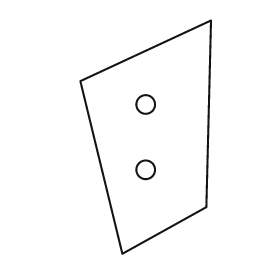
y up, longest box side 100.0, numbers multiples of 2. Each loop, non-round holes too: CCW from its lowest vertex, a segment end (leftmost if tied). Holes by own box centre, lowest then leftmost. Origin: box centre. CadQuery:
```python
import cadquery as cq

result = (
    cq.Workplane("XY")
    .moveTo(-10.0, -50.0)
    .lineTo(26.0, -30.0)
    .lineTo(28.0, 50.0)
    .lineTo(-28.0, 24.0)
    .close()
    .moveTo(0.0, -14.0)
    .circle(4.0)
    .moveTo(0.0, 14.0)
    .circle(4.0)
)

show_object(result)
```